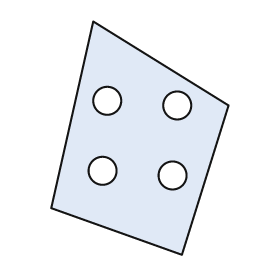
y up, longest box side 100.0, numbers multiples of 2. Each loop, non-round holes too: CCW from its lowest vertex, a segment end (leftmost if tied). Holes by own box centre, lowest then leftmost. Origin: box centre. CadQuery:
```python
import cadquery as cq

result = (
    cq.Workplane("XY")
    .moveTo(18.0, -50.0)
    .lineTo(38.0, 14.0)
    .lineTo(-20.0, 50.0)
    .lineTo(-38.0, -30.0)
    .close()
    .moveTo(14.0, -16.0)
    .circle(6.0)
    .moveTo(-16.0, -14.0)
    .circle(6.0)
    .moveTo(16.0, 14.0)
    .circle(6.0)
    .moveTo(-14.0, 16.0)
    .circle(6.0)
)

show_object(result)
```